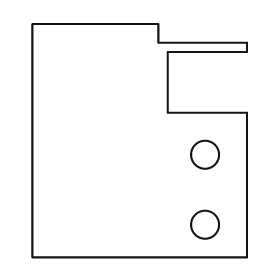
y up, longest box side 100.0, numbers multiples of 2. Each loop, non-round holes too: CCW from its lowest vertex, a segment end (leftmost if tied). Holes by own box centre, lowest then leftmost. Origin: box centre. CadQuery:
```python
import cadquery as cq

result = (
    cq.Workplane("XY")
    .moveTo(-46.0, -50.0)
    .lineTo(46.0, -50.0)
    .lineTo(46.0, 12.0)
    .lineTo(12.0, 12.0)
    .lineTo(12.0, 38.0)
    .lineTo(46.0, 38.0)
    .lineTo(46.0, 42.0)
    .lineTo(8.0, 42.0)
    .lineTo(8.0, 50.0)
    .lineTo(-46.0, 50.0)
    .close()
    .moveTo(28.0, -36.0)
    .circle(6.0)
    .moveTo(28.0, -6.0)
    .circle(6.0)
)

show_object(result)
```